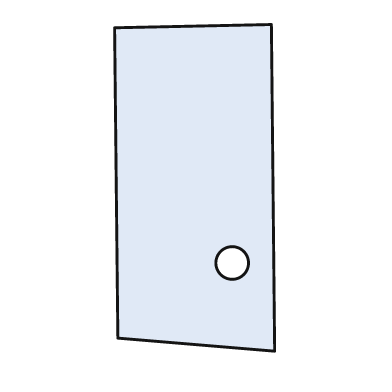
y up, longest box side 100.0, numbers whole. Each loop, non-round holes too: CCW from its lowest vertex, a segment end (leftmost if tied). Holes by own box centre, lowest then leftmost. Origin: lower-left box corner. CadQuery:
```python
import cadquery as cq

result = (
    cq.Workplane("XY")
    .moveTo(49.0, 0.0)
    .lineTo(48.0, 100.0)
    .lineTo(0.0, 99.0)
    .lineTo(1.0, 4.0)
    .close()
    .moveTo(36.0, 27.0)
    .circle(5.0)
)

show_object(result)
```